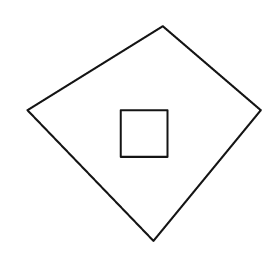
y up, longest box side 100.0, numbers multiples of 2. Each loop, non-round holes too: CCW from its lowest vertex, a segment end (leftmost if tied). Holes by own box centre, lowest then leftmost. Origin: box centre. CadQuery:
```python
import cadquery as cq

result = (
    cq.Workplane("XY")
    .moveTo(4.0, -46.0)
    .lineTo(50.0, 10.0)
    .lineTo(8.0, 46.0)
    .lineTo(-50.0, 10.0)
    .close()
    .moveTo(-10.0, -10.0)
    .lineTo(10.0, -10.0)
    .lineTo(10.0, 10.0)
    .lineTo(-10.0, 10.0)
    .close()
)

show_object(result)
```